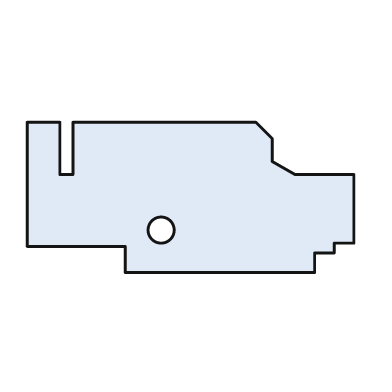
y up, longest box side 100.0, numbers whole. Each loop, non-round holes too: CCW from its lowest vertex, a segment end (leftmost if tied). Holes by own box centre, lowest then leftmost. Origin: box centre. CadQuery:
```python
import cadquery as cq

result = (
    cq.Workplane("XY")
    .moveTo(-20.0, -23.0)
    .lineTo(38.0, -23.0)
    .lineTo(38.0, -17.0)
    .lineTo(44.0, -17.0)
    .lineTo(44.0, -14.0)
    .lineTo(50.0, -14.0)
    .lineTo(50.0, 7.0)
    .lineTo(32.0, 7.0)
    .lineTo(25.0, 11.0)
    .lineTo(25.0, 18.0)
    .lineTo(20.0, 23.0)
    .lineTo(-36.0, 23.0)
    .lineTo(-36.0, 7.0)
    .lineTo(-40.0, 7.0)
    .lineTo(-40.0, 23.0)
    .lineTo(-50.0, 23.0)
    .lineTo(-50.0, -15.0)
    .lineTo(-20.0, -15.0)
    .close()
    .moveTo(-9.0, -10.0)
    .circle(4.0)
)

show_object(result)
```